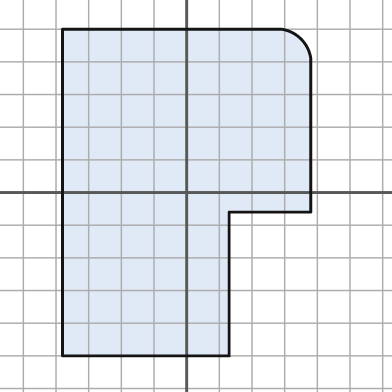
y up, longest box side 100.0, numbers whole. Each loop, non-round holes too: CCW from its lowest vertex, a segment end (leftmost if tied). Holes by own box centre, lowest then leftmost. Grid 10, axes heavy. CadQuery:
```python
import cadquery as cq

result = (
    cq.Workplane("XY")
    .moveTo(-38.0, -50.0)
    .lineTo(13.0, -50.0)
    .lineTo(13.0, -6.0)
    .lineTo(38.0, -6.0)
    .lineTo(38.0, 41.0)
    .threePointArc((35.0, 47.0), (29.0, 50.0))
    .lineTo(-38.0, 50.0)
    .close()
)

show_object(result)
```